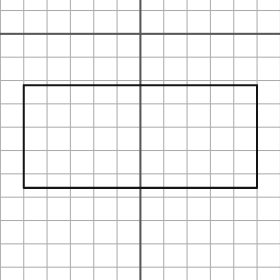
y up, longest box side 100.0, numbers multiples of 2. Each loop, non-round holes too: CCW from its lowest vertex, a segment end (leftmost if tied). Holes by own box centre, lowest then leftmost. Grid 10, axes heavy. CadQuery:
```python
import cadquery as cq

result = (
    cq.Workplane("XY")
    .moveTo(-50.0, -66.0)
    .lineTo(50.0, -66.0)
    .lineTo(50.0, -22.0)
    .lineTo(-50.0, -22.0)
    .close()
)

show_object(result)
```